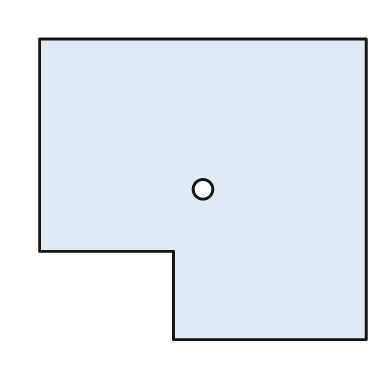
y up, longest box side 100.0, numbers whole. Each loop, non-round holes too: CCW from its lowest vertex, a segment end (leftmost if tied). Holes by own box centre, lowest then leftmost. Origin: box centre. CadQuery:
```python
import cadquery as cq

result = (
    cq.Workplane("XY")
    .moveTo(-9.0, -46.0)
    .lineTo(50.0, -46.0)
    .lineTo(50.0, 46.0)
    .lineTo(-50.0, 46.0)
    .lineTo(-50.0, -19.0)
    .lineTo(-9.0, -19.0)
    .close()
    .moveTo(0.0, 0.0)
    .circle(3.0)
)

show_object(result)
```